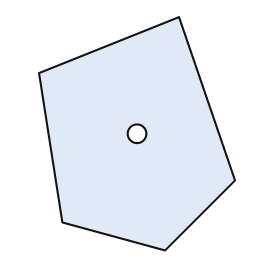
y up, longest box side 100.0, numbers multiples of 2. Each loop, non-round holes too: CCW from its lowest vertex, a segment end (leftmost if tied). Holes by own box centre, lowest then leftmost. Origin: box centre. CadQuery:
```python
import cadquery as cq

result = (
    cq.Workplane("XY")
    .moveTo(12.0, -50.0)
    .lineTo(42.0, -20.0)
    .lineTo(18.0, 50.0)
    .lineTo(-42.0, 26.0)
    .lineTo(-32.0, -38.0)
    .close()
    .moveTo(0.0, 0.0)
    .circle(4.0)
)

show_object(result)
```